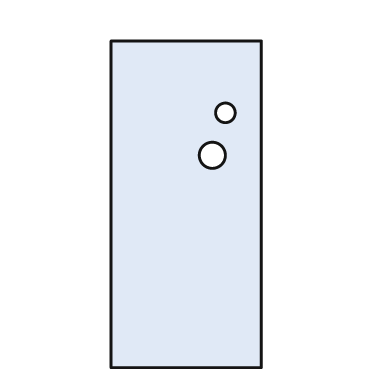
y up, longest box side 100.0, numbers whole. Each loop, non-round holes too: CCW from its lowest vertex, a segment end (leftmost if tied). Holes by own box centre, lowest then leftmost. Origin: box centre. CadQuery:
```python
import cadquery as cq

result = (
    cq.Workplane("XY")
    .moveTo(-23.0, -50.0)
    .lineTo(23.0, -50.0)
    .lineTo(23.0, 50.0)
    .lineTo(-23.0, 50.0)
    .close()
    .moveTo(8.0, 15.0)
    .circle(4.0)
    .moveTo(12.0, 28.0)
    .circle(3.0)
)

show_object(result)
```